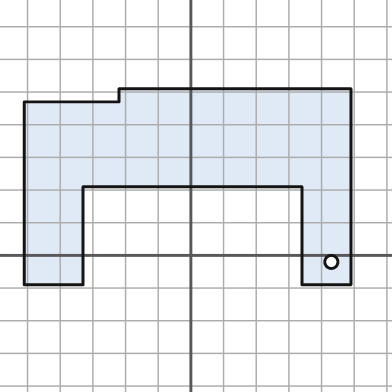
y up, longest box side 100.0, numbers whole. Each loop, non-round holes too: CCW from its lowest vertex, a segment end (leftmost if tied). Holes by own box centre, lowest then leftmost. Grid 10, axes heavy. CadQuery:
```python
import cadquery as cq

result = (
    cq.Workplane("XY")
    .moveTo(-51.0, -9.0)
    .lineTo(-33.0, -9.0)
    .lineTo(-33.0, 21.0)
    .lineTo(34.0, 21.0)
    .lineTo(34.0, -9.0)
    .lineTo(49.0, -9.0)
    .lineTo(49.0, 51.0)
    .lineTo(-22.0, 51.0)
    .lineTo(-22.0, 47.0)
    .lineTo(-51.0, 47.0)
    .close()
    .moveTo(43.0, -2.0)
    .circle(2.0)
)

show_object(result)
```